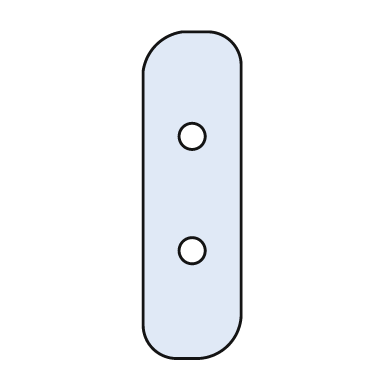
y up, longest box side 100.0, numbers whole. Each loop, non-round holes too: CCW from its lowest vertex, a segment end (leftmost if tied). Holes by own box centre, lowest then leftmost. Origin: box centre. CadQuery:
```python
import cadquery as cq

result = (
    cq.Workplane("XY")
    .moveTo(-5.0, -50.0)
    .lineTo(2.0, -50.0)
    .threePointArc((11.0, -46.0), (15.0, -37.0))
    .lineTo(15.0, 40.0)
    .threePointArc((12.0, 47.0), (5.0, 50.0))
    .lineTo(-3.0, 50.0)
    .threePointArc((-11.0, 46.0), (-15.0, 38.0))
    .lineTo(-15.0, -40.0)
    .threePointArc((-12.0, -47.0), (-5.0, -50.0))
    .close()
    .moveTo(0.0, -17.0)
    .circle(4.0)
    .moveTo(0.0, 18.0)
    .circle(4.0)
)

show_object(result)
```